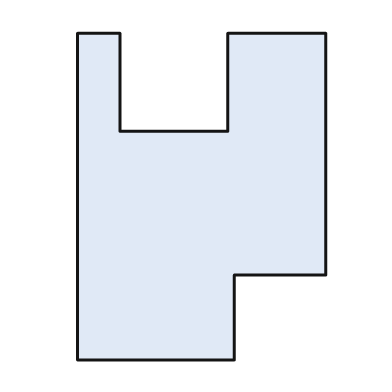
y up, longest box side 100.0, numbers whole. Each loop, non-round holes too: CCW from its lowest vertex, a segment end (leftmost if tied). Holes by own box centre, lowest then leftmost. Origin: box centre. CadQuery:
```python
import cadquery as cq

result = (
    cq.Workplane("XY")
    .moveTo(-38.0, -50.0)
    .lineTo(10.0, -50.0)
    .lineTo(10.0, -24.0)
    .lineTo(38.0, -24.0)
    .lineTo(38.0, 50.0)
    .lineTo(8.0, 50.0)
    .lineTo(8.0, 20.0)
    .lineTo(-25.0, 20.0)
    .lineTo(-25.0, 50.0)
    .lineTo(-38.0, 50.0)
    .close()
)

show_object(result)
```